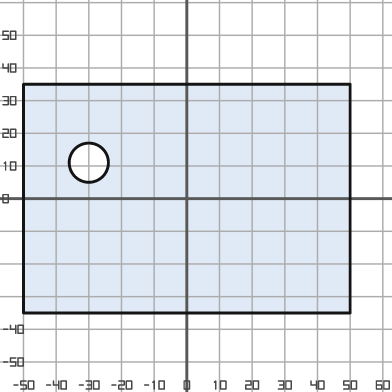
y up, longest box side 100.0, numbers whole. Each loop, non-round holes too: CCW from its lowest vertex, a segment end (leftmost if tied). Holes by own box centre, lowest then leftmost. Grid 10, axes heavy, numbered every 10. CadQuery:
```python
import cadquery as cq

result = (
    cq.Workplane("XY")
    .moveTo(-50.0, -35.0)
    .lineTo(50.0, -35.0)
    .lineTo(50.0, 35.0)
    .lineTo(-50.0, 35.0)
    .close()
    .moveTo(-30.0, 11.0)
    .circle(6.0)
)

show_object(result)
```